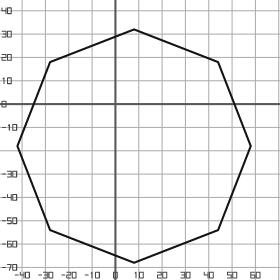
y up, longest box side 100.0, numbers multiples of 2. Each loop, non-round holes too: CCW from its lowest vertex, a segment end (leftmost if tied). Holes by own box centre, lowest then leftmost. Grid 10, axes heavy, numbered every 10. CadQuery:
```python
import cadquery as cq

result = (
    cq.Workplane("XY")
    .moveTo(8.0, -68.0)
    .lineTo(44.0, -54.0)
    .lineTo(58.0, -18.0)
    .lineTo(44.0, 18.0)
    .lineTo(8.0, 32.0)
    .lineTo(-28.0, 18.0)
    .lineTo(-42.0, -18.0)
    .lineTo(-28.0, -54.0)
    .close()
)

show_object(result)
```